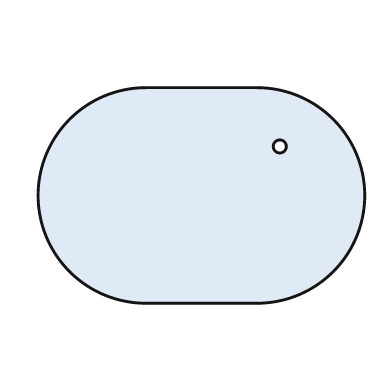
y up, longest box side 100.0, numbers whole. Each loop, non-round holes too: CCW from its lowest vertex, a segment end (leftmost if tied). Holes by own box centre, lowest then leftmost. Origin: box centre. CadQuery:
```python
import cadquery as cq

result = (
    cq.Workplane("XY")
    .moveTo(-17.0, -33.0)
    .lineTo(17.0, -33.0)
    .threePointArc((50.0, 0.0), (17.0, 33.0))
    .lineTo(-17.0, 33.0)
    .threePointArc((-50.0, 0.0), (-17.0, -33.0))
    .close()
    .moveTo(24.0, 15.0)
    .circle(2.0)
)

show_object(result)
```